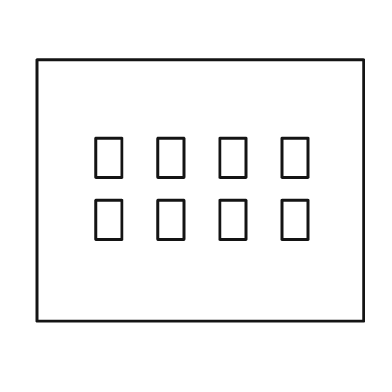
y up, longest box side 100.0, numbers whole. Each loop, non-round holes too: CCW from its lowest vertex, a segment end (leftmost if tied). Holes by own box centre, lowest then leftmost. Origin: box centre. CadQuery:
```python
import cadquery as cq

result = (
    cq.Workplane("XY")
    .moveTo(-50.0, -40.0)
    .lineTo(50.0, -40.0)
    .lineTo(50.0, 40.0)
    .lineTo(-50.0, 40.0)
    .close()
    .moveTo(-32.0, -15.0)
    .lineTo(-24.0, -15.0)
    .lineTo(-24.0, -3.0)
    .lineTo(-32.0, -3.0)
    .close()
    .moveTo(-13.0, -15.0)
    .lineTo(-5.0, -15.0)
    .lineTo(-5.0, -3.0)
    .lineTo(-13.0, -3.0)
    .close()
    .moveTo(6.0, -15.0)
    .lineTo(14.0, -15.0)
    .lineTo(14.0, -3.0)
    .lineTo(6.0, -3.0)
    .close()
    .moveTo(25.0, -15.0)
    .lineTo(33.0, -15.0)
    .lineTo(33.0, -3.0)
    .lineTo(25.0, -3.0)
    .close()
    .moveTo(-32.0, 4.0)
    .lineTo(-24.0, 4.0)
    .lineTo(-24.0, 16.0)
    .lineTo(-32.0, 16.0)
    .close()
    .moveTo(-13.0, 4.0)
    .lineTo(-5.0, 4.0)
    .lineTo(-5.0, 16.0)
    .lineTo(-13.0, 16.0)
    .close()
    .moveTo(6.0, 4.0)
    .lineTo(14.0, 4.0)
    .lineTo(14.0, 16.0)
    .lineTo(6.0, 16.0)
    .close()
    .moveTo(25.0, 4.0)
    .lineTo(33.0, 4.0)
    .lineTo(33.0, 16.0)
    .lineTo(25.0, 16.0)
    .close()
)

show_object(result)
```